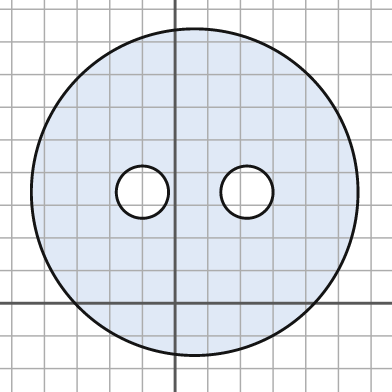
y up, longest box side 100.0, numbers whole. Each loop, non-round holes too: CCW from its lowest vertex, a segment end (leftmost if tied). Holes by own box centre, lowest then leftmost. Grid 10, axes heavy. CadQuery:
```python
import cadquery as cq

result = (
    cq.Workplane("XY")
    .moveTo(6.0, 34.0)
    .circle(50.0)
    .moveTo(-10.0, 34.0)
    .circle(8.0)
    .moveTo(22.0, 34.0)
    .circle(8.0)
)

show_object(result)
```